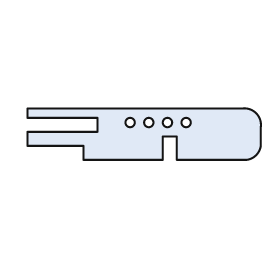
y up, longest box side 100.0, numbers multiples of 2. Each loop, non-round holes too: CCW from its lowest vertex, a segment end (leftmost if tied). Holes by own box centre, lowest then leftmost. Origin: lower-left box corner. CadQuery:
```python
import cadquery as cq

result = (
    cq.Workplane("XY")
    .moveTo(24.0, 0.0)
    .lineTo(58.0, 0.0)
    .lineTo(58.0, 10.0)
    .lineTo(64.0, 10.0)
    .lineTo(64.0, 0.0)
    .lineTo(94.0, 0.0)
    .threePointArc((98.0, 2.0), (100.0, 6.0))
    .lineTo(100.0, 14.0)
    .threePointArc((98.0, 20.0), (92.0, 22.0))
    .lineTo(0.0, 22.0)
    .lineTo(0.0, 18.0)
    .lineTo(30.0, 18.0)
    .lineTo(30.0, 12.0)
    .lineTo(0.0, 12.0)
    .lineTo(0.0, 6.0)
    .lineTo(24.0, 6.0)
    .close()
    .moveTo(44.0, 16.0)
    .circle(2.0)
    .moveTo(52.0, 16.0)
    .circle(2.0)
    .moveTo(60.0, 16.0)
    .circle(2.0)
    .moveTo(68.0, 16.0)
    .circle(2.0)
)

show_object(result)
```